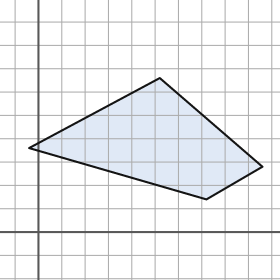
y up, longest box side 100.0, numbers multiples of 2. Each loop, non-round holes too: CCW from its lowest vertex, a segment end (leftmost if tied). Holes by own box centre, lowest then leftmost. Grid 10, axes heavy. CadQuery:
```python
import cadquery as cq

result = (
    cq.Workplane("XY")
    .moveTo(72.0, 14.0)
    .lineTo(96.0, 28.0)
    .lineTo(52.0, 66.0)
    .lineTo(-4.0, 36.0)
    .close()
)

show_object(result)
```